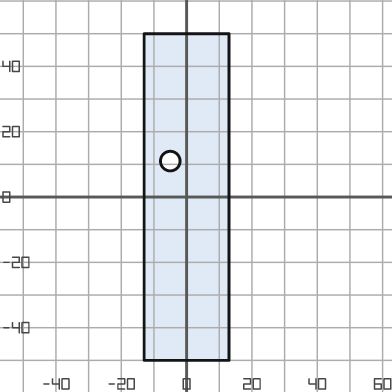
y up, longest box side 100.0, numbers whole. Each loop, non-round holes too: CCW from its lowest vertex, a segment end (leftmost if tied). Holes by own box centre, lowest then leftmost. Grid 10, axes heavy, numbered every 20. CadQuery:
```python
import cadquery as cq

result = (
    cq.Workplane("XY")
    .moveTo(-13.0, -50.0)
    .lineTo(13.0, -50.0)
    .lineTo(13.0, 50.0)
    .lineTo(-13.0, 50.0)
    .close()
    .moveTo(-5.0, 11.0)
    .circle(3.0)
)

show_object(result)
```